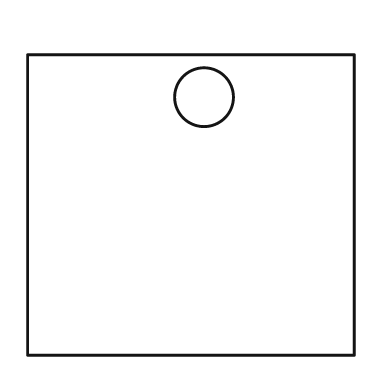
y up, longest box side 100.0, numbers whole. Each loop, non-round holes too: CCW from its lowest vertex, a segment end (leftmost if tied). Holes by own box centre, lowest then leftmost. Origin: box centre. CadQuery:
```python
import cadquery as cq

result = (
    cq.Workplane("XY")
    .moveTo(-50.0, -46.0)
    .lineTo(50.0, -46.0)
    .lineTo(50.0, 46.0)
    .lineTo(-50.0, 46.0)
    .close()
    .moveTo(4.0, 33.0)
    .circle(9.0)
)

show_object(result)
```